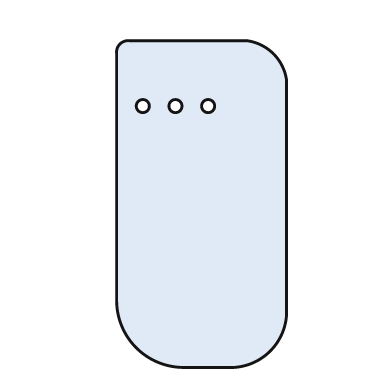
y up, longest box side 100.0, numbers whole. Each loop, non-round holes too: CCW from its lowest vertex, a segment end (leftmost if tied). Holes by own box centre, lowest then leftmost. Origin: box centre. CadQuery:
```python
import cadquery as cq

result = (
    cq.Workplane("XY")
    .moveTo(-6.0, -50.0)
    .lineTo(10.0, -50.0)
    .threePointArc((21.0, -45.0), (26.0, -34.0))
    .lineTo(26.0, 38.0)
    .threePointArc((22.0, 46.0), (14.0, 50.0))
    .lineTo(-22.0, 50.0)
    .threePointArc((-25.0, 49.0), (-26.0, 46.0))
    .lineTo(-26.0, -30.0)
    .threePointArc((-20.0, -44.0), (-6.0, -50.0))
    .close()
    .moveTo(-18.0, 30.0)
    .circle(2.0)
    .moveTo(-8.0, 30.0)
    .circle(2.0)
    .moveTo(2.0, 30.0)
    .circle(2.0)
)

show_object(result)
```